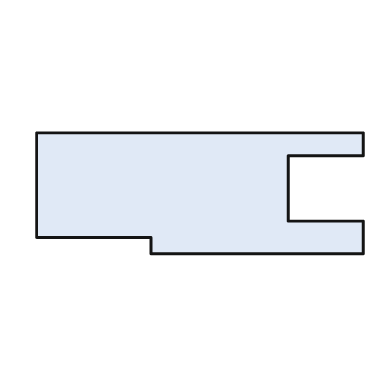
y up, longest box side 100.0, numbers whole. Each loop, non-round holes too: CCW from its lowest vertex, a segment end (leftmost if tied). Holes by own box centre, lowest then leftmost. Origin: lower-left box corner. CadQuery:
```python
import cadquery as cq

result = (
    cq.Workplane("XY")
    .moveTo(35.0, 0.0)
    .lineTo(100.0, 0.0)
    .lineTo(100.0, 10.0)
    .lineTo(77.0, 10.0)
    .lineTo(77.0, 30.0)
    .lineTo(100.0, 30.0)
    .lineTo(100.0, 37.0)
    .lineTo(0.0, 37.0)
    .lineTo(0.0, 5.0)
    .lineTo(35.0, 5.0)
    .close()
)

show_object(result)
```